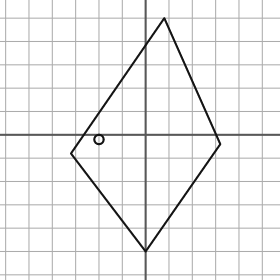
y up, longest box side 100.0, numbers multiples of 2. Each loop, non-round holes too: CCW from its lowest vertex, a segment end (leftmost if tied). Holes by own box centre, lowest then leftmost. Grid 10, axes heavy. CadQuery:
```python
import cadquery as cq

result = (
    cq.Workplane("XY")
    .moveTo(0.0, -50.0)
    .lineTo(32.0, -4.0)
    .lineTo(8.0, 50.0)
    .lineTo(-32.0, -8.0)
    .close()
    .moveTo(-20.0, -2.0)
    .circle(2.0)
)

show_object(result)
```